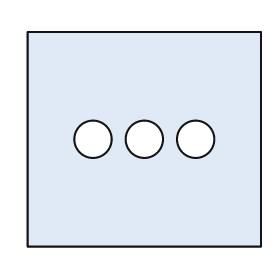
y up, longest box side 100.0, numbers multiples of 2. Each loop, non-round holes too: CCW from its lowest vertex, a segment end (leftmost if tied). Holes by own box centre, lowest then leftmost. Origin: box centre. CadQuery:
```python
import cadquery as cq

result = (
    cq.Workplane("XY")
    .moveTo(-50.0, -46.0)
    .lineTo(50.0, -46.0)
    .lineTo(50.0, 46.0)
    .lineTo(-50.0, 46.0)
    .close()
    .moveTo(-22.0, 0.0)
    .circle(8.0)
    .moveTo(0.0, 0.0)
    .circle(8.0)
    .moveTo(22.0, 0.0)
    .circle(8.0)
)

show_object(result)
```